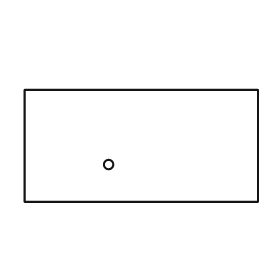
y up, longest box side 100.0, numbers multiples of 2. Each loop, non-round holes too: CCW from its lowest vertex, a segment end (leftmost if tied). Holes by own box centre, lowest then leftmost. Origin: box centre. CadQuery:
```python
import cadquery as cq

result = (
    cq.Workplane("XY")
    .moveTo(-50.0, -24.0)
    .lineTo(50.0, -24.0)
    .lineTo(50.0, 24.0)
    .lineTo(-50.0, 24.0)
    .close()
    .moveTo(-14.0, -8.0)
    .circle(2.0)
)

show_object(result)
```